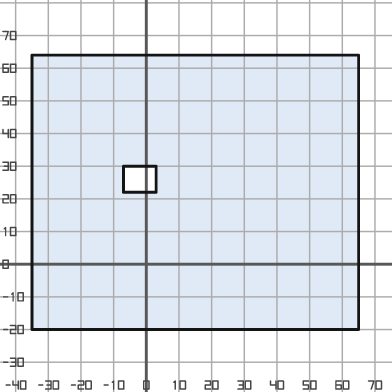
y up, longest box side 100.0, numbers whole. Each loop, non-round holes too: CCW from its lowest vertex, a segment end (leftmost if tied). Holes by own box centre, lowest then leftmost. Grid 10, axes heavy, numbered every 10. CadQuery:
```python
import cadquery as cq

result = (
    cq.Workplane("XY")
    .moveTo(-35.0, -20.0)
    .lineTo(65.0, -20.0)
    .lineTo(65.0, 64.0)
    .lineTo(-35.0, 64.0)
    .close()
    .moveTo(-7.0, 22.0)
    .lineTo(3.0, 22.0)
    .lineTo(3.0, 30.0)
    .lineTo(-7.0, 30.0)
    .close()
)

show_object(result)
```